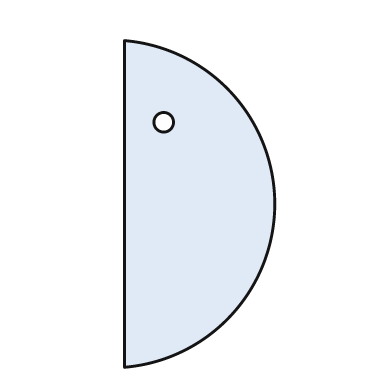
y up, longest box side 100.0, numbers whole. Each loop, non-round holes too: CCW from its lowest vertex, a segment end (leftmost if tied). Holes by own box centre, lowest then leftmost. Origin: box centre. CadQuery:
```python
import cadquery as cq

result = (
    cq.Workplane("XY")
    .moveTo(-23.0, -50.0)
    .threePointArc((23.0, 0.0), (-23.0, 50.0))
    .close()
    .moveTo(-11.0, 25.0)
    .circle(3.0)
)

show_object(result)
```